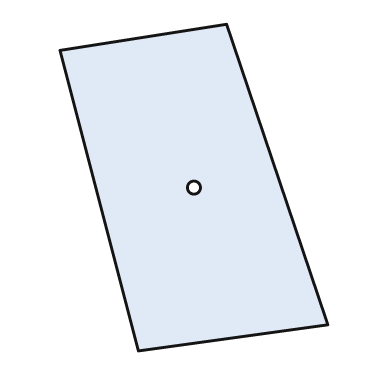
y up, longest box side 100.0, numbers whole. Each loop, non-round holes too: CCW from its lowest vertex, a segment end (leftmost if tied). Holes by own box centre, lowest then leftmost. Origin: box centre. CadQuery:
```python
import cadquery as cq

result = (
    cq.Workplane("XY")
    .moveTo(-17.0, -50.0)
    .lineTo(41.0, -42.0)
    .lineTo(10.0, 50.0)
    .lineTo(-41.0, 42.0)
    .close()
    .moveTo(0.0, 0.0)
    .circle(2.0)
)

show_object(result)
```